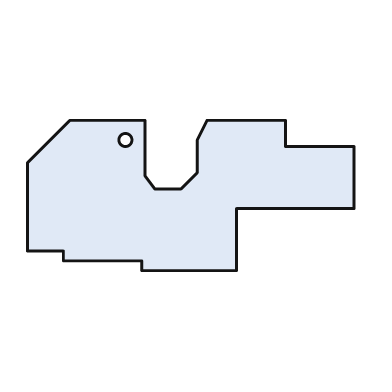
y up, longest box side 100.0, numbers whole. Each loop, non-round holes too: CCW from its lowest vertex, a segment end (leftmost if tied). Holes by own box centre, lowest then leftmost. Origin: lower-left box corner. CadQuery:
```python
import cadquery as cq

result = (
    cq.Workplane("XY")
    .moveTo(35.0, 0.0)
    .lineTo(64.0, 0.0)
    .lineTo(64.0, 19.0)
    .lineTo(100.0, 19.0)
    .lineTo(100.0, 38.0)
    .lineTo(79.0, 38.0)
    .lineTo(79.0, 46.0)
    .lineTo(55.0, 46.0)
    .lineTo(52.0, 40.0)
    .lineTo(52.0, 30.0)
    .lineTo(47.0, 25.0)
    .lineTo(39.0, 25.0)
    .lineTo(36.0, 29.0)
    .lineTo(36.0, 46.0)
    .lineTo(13.0, 46.0)
    .lineTo(0.0, 33.0)
    .lineTo(0.0, 6.0)
    .lineTo(11.0, 6.0)
    .lineTo(11.0, 3.0)
    .lineTo(35.0, 3.0)
    .close()
    .moveTo(30.0, 40.0)
    .circle(2.0)
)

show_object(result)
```